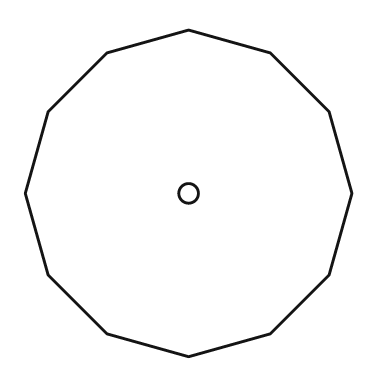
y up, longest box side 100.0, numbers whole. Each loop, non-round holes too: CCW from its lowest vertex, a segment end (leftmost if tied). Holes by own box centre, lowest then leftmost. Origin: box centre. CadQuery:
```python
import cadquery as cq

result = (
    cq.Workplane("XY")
    .moveTo(0.0, -50.0)
    .lineTo(25.0, -43.0)
    .lineTo(43.0, -25.0)
    .lineTo(50.0, 0.0)
    .lineTo(43.0, 25.0)
    .lineTo(25.0, 43.0)
    .lineTo(0.0, 50.0)
    .lineTo(-25.0, 43.0)
    .lineTo(-43.0, 25.0)
    .lineTo(-50.0, 0.0)
    .lineTo(-43.0, -25.0)
    .lineTo(-25.0, -43.0)
    .close()
    .moveTo(0.0, 0.0)
    .circle(3.0)
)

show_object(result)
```